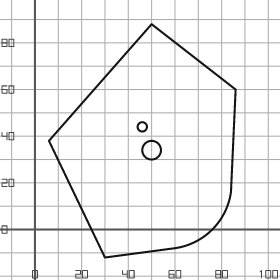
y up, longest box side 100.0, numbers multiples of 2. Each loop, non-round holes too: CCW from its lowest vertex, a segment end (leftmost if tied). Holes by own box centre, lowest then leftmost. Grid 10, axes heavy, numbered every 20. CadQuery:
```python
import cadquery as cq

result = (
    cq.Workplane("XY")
    .moveTo(30.0, -12.0)
    .lineTo(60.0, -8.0)
    .threePointArc((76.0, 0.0), (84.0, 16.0))
    .lineTo(86.0, 60.0)
    .lineTo(50.0, 88.0)
    .lineTo(6.0, 38.0)
    .close()
    .moveTo(50.0, 34.0)
    .circle(4.0)
    .moveTo(46.0, 44.0)
    .circle(2.0)
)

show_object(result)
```